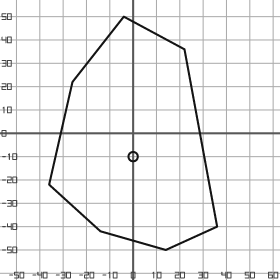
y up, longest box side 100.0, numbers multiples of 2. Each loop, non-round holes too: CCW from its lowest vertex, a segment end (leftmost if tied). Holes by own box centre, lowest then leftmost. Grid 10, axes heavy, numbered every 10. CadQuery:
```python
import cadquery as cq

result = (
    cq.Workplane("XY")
    .moveTo(14.0, -50.0)
    .lineTo(36.0, -40.0)
    .lineTo(22.0, 36.0)
    .lineTo(-4.0, 50.0)
    .lineTo(-26.0, 22.0)
    .lineTo(-36.0, -22.0)
    .lineTo(-14.0, -42.0)
    .close()
    .moveTo(0.0, -10.0)
    .circle(2.0)
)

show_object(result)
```